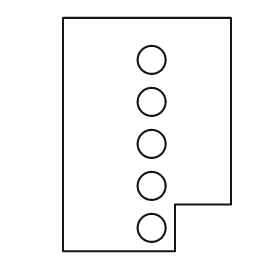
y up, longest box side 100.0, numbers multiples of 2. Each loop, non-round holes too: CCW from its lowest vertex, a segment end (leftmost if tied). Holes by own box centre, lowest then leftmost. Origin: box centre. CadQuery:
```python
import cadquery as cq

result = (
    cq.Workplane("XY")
    .moveTo(-36.0, -50.0)
    .lineTo(12.0, -50.0)
    .lineTo(12.0, -30.0)
    .lineTo(36.0, -30.0)
    .lineTo(36.0, 50.0)
    .lineTo(-36.0, 50.0)
    .close()
    .moveTo(2.0, -40.0)
    .circle(6.0)
    .moveTo(2.0, -22.0)
    .circle(6.0)
    .moveTo(2.0, -4.0)
    .circle(6.0)
    .moveTo(2.0, 14.0)
    .circle(6.0)
    .moveTo(2.0, 32.0)
    .circle(6.0)
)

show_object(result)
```